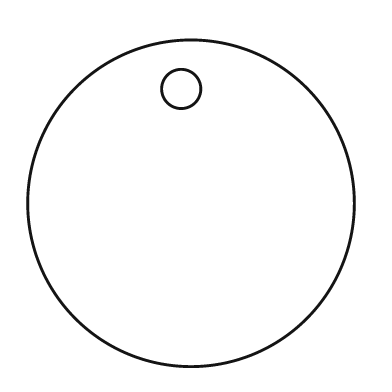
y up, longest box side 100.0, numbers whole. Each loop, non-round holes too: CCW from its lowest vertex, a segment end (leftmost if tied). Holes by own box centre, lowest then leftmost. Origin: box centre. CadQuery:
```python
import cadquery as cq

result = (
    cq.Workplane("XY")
    .moveTo(0.0, 0.0)
    .circle(50.0)
    .moveTo(-3.0, 35.0)
    .circle(6.0)
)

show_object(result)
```